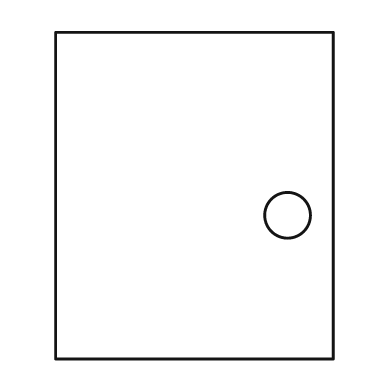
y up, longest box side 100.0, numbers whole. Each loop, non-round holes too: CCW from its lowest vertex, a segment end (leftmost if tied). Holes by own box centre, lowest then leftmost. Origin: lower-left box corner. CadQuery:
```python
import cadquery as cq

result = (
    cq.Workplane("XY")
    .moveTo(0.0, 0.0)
    .lineTo(85.0, 0.0)
    .lineTo(85.0, 100.0)
    .lineTo(0.0, 100.0)
    .close()
    .moveTo(71.0, 44.0)
    .circle(7.0)
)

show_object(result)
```